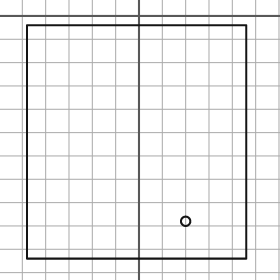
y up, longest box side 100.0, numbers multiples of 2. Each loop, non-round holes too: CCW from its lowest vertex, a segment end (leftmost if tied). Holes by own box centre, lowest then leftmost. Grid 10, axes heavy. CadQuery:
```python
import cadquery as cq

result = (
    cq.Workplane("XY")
    .moveTo(-48.0, -104.0)
    .lineTo(46.0, -104.0)
    .lineTo(46.0, -4.0)
    .lineTo(-48.0, -4.0)
    .close()
    .moveTo(20.0, -88.0)
    .circle(2.0)
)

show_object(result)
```